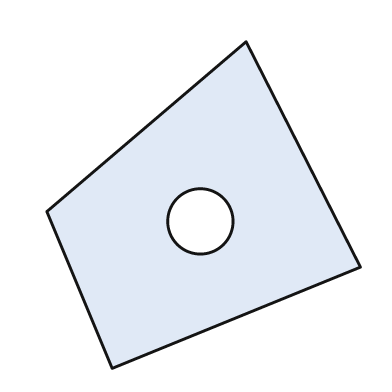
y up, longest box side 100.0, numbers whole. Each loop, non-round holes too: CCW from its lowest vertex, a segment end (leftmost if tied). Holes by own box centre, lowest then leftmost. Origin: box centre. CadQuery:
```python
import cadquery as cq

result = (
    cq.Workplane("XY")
    .moveTo(-28.0, -50.0)
    .lineTo(48.0, -19.0)
    .lineTo(13.0, 50.0)
    .lineTo(-48.0, -2.0)
    .close()
    .moveTo(-1.0, -5.0)
    .circle(10.0)
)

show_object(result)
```